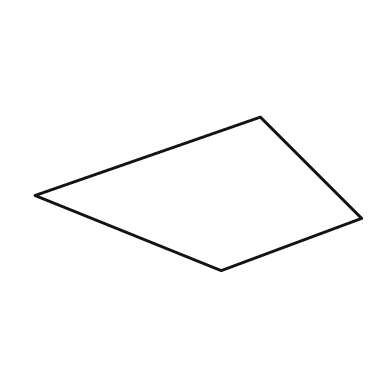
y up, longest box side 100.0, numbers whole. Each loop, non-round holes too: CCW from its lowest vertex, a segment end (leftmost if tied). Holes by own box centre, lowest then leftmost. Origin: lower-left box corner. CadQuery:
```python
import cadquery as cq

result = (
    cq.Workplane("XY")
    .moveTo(57.0, 0.0)
    .lineTo(100.0, 16.0)
    .lineTo(69.0, 47.0)
    .lineTo(0.0, 23.0)
    .close()
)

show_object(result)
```